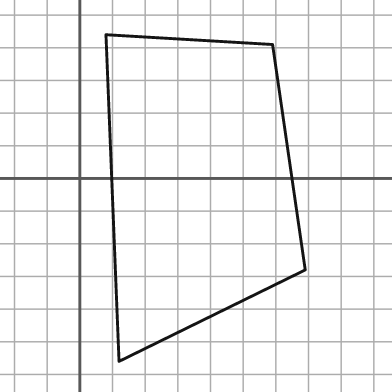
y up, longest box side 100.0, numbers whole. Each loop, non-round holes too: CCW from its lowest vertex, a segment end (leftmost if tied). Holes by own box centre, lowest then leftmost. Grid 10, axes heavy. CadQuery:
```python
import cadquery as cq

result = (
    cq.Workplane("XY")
    .moveTo(12.0, -56.0)
    .lineTo(69.0, -28.0)
    .lineTo(59.0, 41.0)
    .lineTo(8.0, 44.0)
    .close()
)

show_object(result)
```